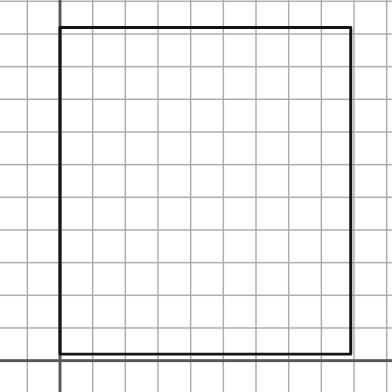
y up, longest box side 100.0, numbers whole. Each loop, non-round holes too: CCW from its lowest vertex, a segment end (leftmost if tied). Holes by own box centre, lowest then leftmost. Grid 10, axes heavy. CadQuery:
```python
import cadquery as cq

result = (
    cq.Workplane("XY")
    .moveTo(0.0, 2.0)
    .lineTo(89.0, 2.0)
    .lineTo(89.0, 102.0)
    .lineTo(0.0, 102.0)
    .close()
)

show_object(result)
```